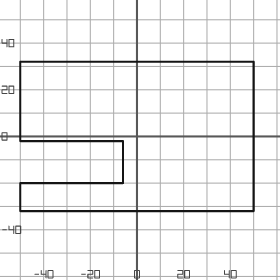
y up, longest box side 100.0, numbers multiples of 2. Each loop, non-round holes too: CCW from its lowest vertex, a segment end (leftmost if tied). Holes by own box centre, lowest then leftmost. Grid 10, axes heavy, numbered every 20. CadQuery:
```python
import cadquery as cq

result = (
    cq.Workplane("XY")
    .moveTo(-50.0, -32.0)
    .lineTo(50.0, -32.0)
    .lineTo(50.0, 32.0)
    .lineTo(-50.0, 32.0)
    .lineTo(-50.0, -2.0)
    .lineTo(-6.0, -2.0)
    .lineTo(-6.0, -20.0)
    .lineTo(-50.0, -20.0)
    .close()
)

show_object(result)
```